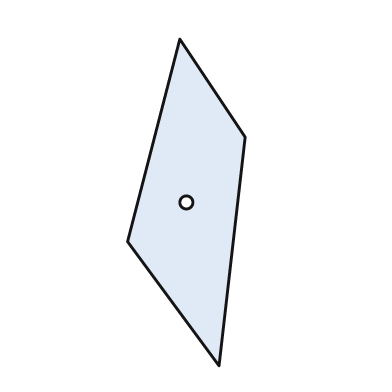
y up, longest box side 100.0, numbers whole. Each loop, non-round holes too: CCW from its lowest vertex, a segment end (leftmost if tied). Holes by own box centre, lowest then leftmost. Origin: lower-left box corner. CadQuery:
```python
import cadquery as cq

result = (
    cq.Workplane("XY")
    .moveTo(28.0, 0.0)
    .lineTo(36.0, 70.0)
    .lineTo(16.0, 100.0)
    .lineTo(0.0, 38.0)
    .close()
    .moveTo(18.0, 50.0)
    .circle(2.0)
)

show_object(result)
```